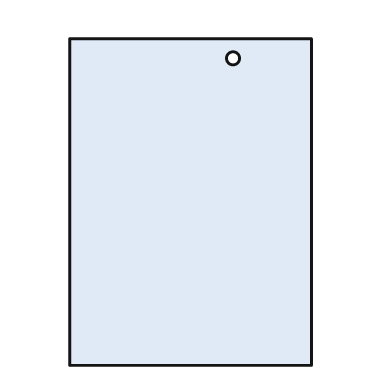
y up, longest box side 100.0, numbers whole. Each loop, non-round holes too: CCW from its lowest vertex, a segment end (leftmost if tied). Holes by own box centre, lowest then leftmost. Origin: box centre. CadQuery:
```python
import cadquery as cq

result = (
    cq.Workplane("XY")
    .moveTo(-37.0, -50.0)
    .lineTo(37.0, -50.0)
    .lineTo(37.0, 50.0)
    .lineTo(-37.0, 50.0)
    .close()
    .moveTo(13.0, 44.0)
    .circle(2.0)
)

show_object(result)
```